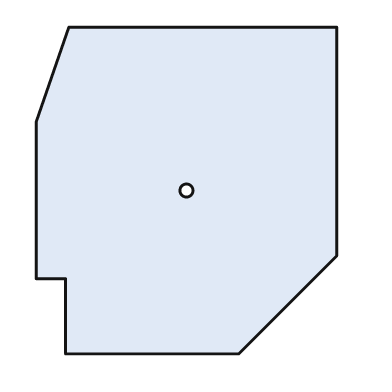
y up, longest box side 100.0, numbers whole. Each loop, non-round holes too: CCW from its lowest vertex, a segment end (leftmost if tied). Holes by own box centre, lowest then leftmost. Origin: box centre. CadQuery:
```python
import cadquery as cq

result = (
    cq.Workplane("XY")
    .moveTo(-37.0, -50.0)
    .lineTo(16.0, -50.0)
    .lineTo(46.0, -20.0)
    .lineTo(46.0, 50.0)
    .lineTo(-36.0, 50.0)
    .lineTo(-46.0, 21.0)
    .lineTo(-46.0, -27.0)
    .lineTo(-37.0, -27.0)
    .close()
    .moveTo(0.0, 0.0)
    .circle(2.0)
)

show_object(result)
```